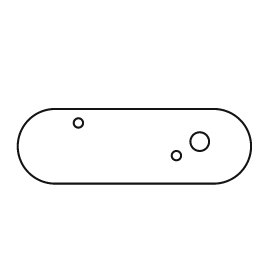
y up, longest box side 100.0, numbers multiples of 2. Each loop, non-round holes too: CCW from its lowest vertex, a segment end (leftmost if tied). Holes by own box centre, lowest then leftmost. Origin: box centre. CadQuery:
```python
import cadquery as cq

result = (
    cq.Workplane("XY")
    .moveTo(-34.0, -16.0)
    .lineTo(34.0, -16.0)
    .threePointArc((50.0, 0.0), (34.0, 16.0))
    .lineTo(-34.0, 16.0)
    .threePointArc((-50.0, 0.0), (-34.0, -16.0))
    .close()
    .moveTo(18.0, -4.0)
    .circle(2.0)
    .moveTo(28.0, 2.0)
    .circle(4.0)
    .moveTo(-24.0, 10.0)
    .circle(2.0)
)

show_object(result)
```